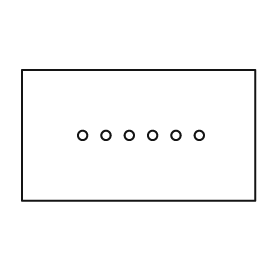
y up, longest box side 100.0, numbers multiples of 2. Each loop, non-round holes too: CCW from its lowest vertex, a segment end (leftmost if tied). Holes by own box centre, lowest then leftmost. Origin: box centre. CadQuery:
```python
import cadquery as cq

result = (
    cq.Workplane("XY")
    .moveTo(-50.0, -28.0)
    .lineTo(50.0, -28.0)
    .lineTo(50.0, 28.0)
    .lineTo(-50.0, 28.0)
    .close()
    .moveTo(-24.0, 0.0)
    .circle(2.0)
    .moveTo(-14.0, 0.0)
    .circle(2.0)
    .moveTo(-4.0, 0.0)
    .circle(2.0)
    .moveTo(6.0, 0.0)
    .circle(2.0)
    .moveTo(16.0, 0.0)
    .circle(2.0)
    .moveTo(26.0, 0.0)
    .circle(2.0)
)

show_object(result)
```